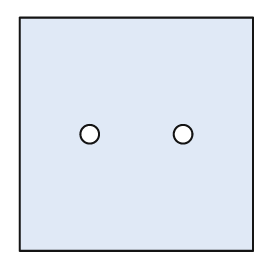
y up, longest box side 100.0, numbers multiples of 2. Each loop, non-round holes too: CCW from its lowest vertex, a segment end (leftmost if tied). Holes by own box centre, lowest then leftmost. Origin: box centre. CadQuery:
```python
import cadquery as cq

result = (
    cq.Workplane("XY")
    .moveTo(-50.0, -50.0)
    .lineTo(50.0, -50.0)
    .lineTo(50.0, 50.0)
    .lineTo(-50.0, 50.0)
    .close()
    .moveTo(-20.0, 0.0)
    .circle(4.0)
    .moveTo(20.0, 0.0)
    .circle(4.0)
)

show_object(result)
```